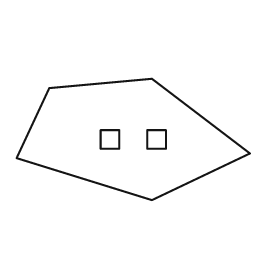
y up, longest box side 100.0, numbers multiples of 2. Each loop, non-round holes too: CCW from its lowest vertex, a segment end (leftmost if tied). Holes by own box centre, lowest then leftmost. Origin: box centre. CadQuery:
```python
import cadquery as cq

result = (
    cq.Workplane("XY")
    .moveTo(8.0, -26.0)
    .lineTo(50.0, -6.0)
    .lineTo(8.0, 26.0)
    .lineTo(-36.0, 22.0)
    .lineTo(-50.0, -8.0)
    .close()
    .moveTo(-14.0, -4.0)
    .lineTo(-6.0, -4.0)
    .lineTo(-6.0, 4.0)
    .lineTo(-14.0, 4.0)
    .close()
    .moveTo(6.0, -4.0)
    .lineTo(14.0, -4.0)
    .lineTo(14.0, 4.0)
    .lineTo(6.0, 4.0)
    .close()
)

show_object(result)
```